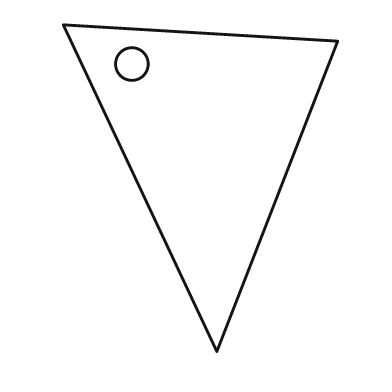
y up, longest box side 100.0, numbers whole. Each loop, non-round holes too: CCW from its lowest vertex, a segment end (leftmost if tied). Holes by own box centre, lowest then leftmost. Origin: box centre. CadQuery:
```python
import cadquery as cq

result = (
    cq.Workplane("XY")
    .moveTo(5.0, -50.0)
    .lineTo(42.0, 45.0)
    .lineTo(-42.0, 50.0)
    .close()
    .moveTo(-21.0, 38.0)
    .circle(5.0)
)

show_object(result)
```